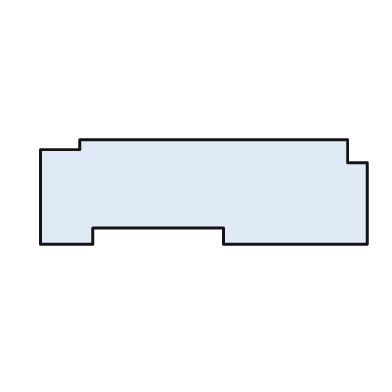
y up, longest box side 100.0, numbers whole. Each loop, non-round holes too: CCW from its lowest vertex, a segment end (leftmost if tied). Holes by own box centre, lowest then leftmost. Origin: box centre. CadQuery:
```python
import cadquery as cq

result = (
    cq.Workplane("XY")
    .moveTo(-50.0, -16.0)
    .lineTo(-34.0, -16.0)
    .lineTo(-34.0, -11.0)
    .lineTo(6.0, -11.0)
    .lineTo(6.0, -16.0)
    .lineTo(50.0, -16.0)
    .lineTo(50.0, 9.0)
    .lineTo(44.0, 9.0)
    .lineTo(44.0, 16.0)
    .lineTo(-38.0, 16.0)
    .lineTo(-38.0, 13.0)
    .lineTo(-50.0, 13.0)
    .close()
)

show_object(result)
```